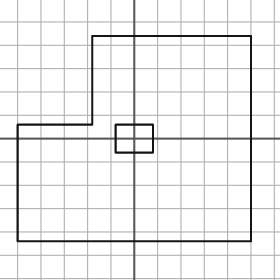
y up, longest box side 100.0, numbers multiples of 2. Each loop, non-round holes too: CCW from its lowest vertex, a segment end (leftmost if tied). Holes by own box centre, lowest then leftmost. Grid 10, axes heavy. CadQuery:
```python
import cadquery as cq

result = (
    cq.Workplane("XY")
    .moveTo(-50.0, -44.0)
    .lineTo(50.0, -44.0)
    .lineTo(50.0, 44.0)
    .lineTo(-18.0, 44.0)
    .lineTo(-18.0, 6.0)
    .lineTo(-50.0, 6.0)
    .close()
    .moveTo(-8.0, -6.0)
    .lineTo(8.0, -6.0)
    .lineTo(8.0, 6.0)
    .lineTo(-8.0, 6.0)
    .close()
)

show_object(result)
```